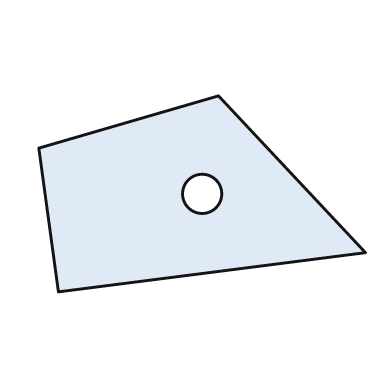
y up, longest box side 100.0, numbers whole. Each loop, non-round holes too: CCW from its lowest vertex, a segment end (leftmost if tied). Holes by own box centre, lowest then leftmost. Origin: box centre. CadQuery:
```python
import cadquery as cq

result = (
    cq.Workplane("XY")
    .moveTo(-44.0, -30.0)
    .lineTo(50.0, -18.0)
    .lineTo(5.0, 30.0)
    .lineTo(-50.0, 14.0)
    .close()
    .moveTo(0.0, 0.0)
    .circle(6.0)
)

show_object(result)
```